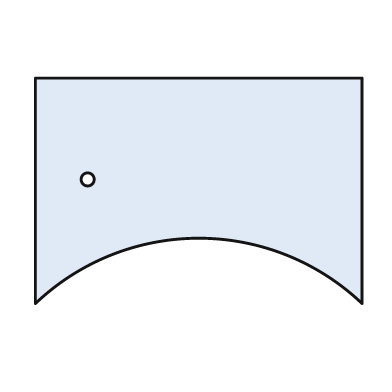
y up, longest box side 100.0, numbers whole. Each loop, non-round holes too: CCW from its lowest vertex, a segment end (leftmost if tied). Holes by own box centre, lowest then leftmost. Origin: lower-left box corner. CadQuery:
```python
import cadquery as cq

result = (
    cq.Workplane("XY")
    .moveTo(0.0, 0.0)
    .threePointArc((50.0, 20.0), (100.0, 0.0))
    .lineTo(100.0, 69.0)
    .lineTo(0.0, 69.0)
    .close()
    .moveTo(16.0, 38.0)
    .circle(2.0)
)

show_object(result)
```